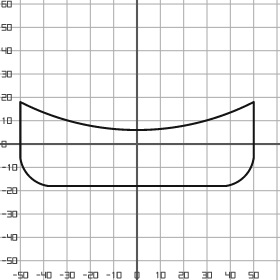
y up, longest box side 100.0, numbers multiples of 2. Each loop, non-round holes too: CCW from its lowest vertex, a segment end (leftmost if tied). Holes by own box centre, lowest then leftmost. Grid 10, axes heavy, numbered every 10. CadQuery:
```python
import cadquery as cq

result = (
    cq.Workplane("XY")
    .moveTo(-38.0, -18.0)
    .lineTo(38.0, -18.0)
    .threePointArc((46.0, -14.0), (50.0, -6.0))
    .lineTo(50.0, 18.0)
    .threePointArc((0.0, 6.0), (-50.0, 18.0))
    .lineTo(-50.0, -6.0)
    .threePointArc((-46.0, -14.0), (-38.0, -18.0))
    .close()
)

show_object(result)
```